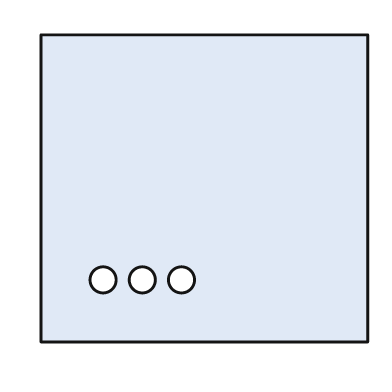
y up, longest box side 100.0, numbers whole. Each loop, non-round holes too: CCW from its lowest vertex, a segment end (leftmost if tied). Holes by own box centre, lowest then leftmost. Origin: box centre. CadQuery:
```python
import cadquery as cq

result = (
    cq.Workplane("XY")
    .moveTo(-50.0, -47.0)
    .lineTo(50.0, -47.0)
    .lineTo(50.0, 47.0)
    .lineTo(-50.0, 47.0)
    .close()
    .moveTo(-31.0, -28.0)
    .circle(4.0)
    .moveTo(-19.0, -28.0)
    .circle(4.0)
    .moveTo(-7.0, -28.0)
    .circle(4.0)
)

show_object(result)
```